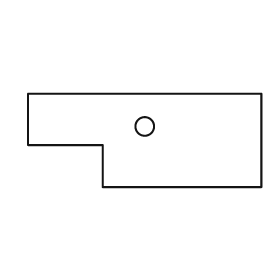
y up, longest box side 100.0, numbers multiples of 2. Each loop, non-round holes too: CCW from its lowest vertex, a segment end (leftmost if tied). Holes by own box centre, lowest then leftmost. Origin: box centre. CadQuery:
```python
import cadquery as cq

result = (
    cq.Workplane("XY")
    .moveTo(-18.0, -20.0)
    .lineTo(50.0, -20.0)
    .lineTo(50.0, 20.0)
    .lineTo(-50.0, 20.0)
    .lineTo(-50.0, -2.0)
    .lineTo(-18.0, -2.0)
    .close()
    .moveTo(0.0, 6.0)
    .circle(4.0)
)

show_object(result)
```